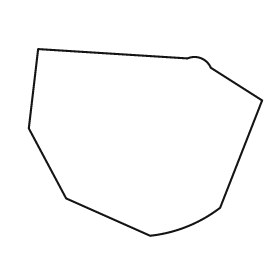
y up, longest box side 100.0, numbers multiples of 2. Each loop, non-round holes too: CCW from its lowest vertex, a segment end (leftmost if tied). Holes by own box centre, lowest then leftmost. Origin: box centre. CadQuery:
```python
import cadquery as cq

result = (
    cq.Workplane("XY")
    .moveTo(2.0, -40.0)
    .threePointArc((18.0, -36.0), (32.0, -28.0))
    .lineTo(50.0, 18.0)
    .lineTo(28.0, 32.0)
    .threePointArc((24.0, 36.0), (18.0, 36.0))
    .lineTo(-46.0, 40.0)
    .lineTo(-50.0, 6.0)
    .lineTo(-34.0, -24.0)
    .close()
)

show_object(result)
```